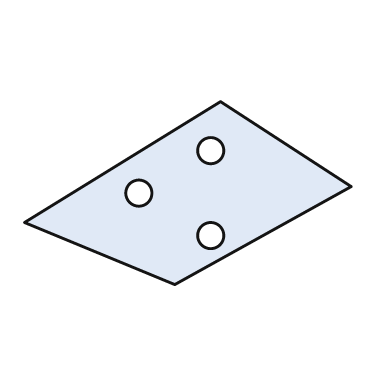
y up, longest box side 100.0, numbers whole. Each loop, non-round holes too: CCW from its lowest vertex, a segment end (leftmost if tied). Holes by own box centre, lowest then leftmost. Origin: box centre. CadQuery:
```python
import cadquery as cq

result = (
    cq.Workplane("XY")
    .moveTo(-4.0, -28.0)
    .lineTo(50.0, 2.0)
    .lineTo(10.0, 28.0)
    .lineTo(-50.0, -9.0)
    .close()
    .moveTo(7.0, -13.0)
    .circle(4.0)
    .moveTo(-15.0, 0.0)
    .circle(4.0)
    .moveTo(7.0, 13.0)
    .circle(4.0)
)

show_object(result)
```